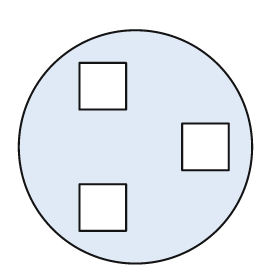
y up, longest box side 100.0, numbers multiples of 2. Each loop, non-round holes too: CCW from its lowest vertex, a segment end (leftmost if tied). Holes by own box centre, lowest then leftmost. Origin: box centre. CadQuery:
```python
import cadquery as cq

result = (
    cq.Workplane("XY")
    .moveTo(0.0, 0.0)
    .circle(50.0)
    .moveTo(-24.0, -36.0)
    .lineTo(-4.0, -36.0)
    .lineTo(-4.0, -16.0)
    .lineTo(-24.0, -16.0)
    .close()
    .moveTo(20.0, -10.0)
    .lineTo(40.0, -10.0)
    .lineTo(40.0, 10.0)
    .lineTo(20.0, 10.0)
    .close()
    .moveTo(-24.0, 16.0)
    .lineTo(-4.0, 16.0)
    .lineTo(-4.0, 36.0)
    .lineTo(-24.0, 36.0)
    .close()
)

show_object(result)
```